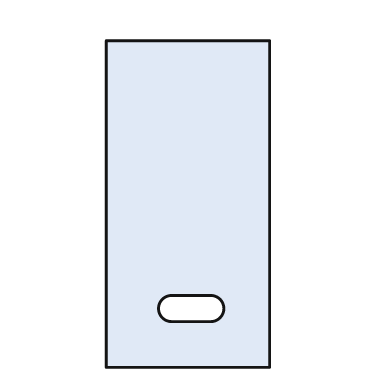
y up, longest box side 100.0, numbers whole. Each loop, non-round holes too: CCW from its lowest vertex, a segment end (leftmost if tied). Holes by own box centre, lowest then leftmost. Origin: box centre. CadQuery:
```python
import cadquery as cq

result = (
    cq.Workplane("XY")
    .moveTo(-25.0, -50.0)
    .lineTo(25.0, -50.0)
    .lineTo(25.0, 50.0)
    .lineTo(-25.0, 50.0)
    .close()
    .moveTo(-5.0, -36.0)
    .lineTo(7.0, -36.0)
    .threePointArc((11.0, -32.0), (7.0, -28.0))
    .lineTo(-5.0, -28.0)
    .threePointArc((-9.0, -32.0), (-5.0, -36.0))
    .close()
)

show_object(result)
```